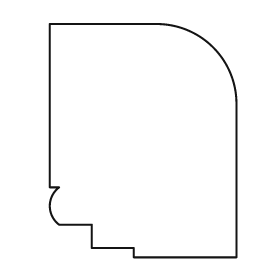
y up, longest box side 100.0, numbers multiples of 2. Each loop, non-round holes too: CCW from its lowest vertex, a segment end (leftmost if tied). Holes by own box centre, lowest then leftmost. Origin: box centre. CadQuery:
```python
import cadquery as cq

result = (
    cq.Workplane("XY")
    .moveTo(-4.0, -50.0)
    .lineTo(40.0, -50.0)
    .lineTo(40.0, 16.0)
    .threePointArc((30.0, 40.0), (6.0, 50.0))
    .lineTo(-40.0, 50.0)
    .lineTo(-40.0, -20.0)
    .lineTo(-36.0, -20.0)
    .threePointArc((-40.0, -28.0), (-36.0, -36.0))
    .lineTo(-22.0, -36.0)
    .lineTo(-22.0, -46.0)
    .lineTo(-4.0, -46.0)
    .close()
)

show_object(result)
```